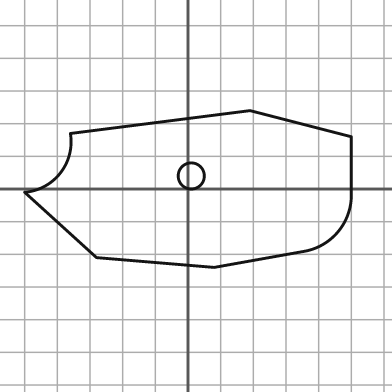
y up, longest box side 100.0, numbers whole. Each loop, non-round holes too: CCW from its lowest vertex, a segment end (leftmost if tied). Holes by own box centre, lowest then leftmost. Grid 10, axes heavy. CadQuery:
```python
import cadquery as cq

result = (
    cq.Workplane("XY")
    .moveTo(8.0, -24.0)
    .lineTo(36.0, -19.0)
    .threePointArc((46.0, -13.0), (50.0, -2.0))
    .lineTo(50.0, 16.0)
    .lineTo(19.0, 24.0)
    .lineTo(-36.0, 17.0)
    .threePointArc((-39.0, 5.0), (-50.0, -1.0))
    .lineTo(-28.0, -21.0)
    .close()
    .moveTo(1.0, 4.0)
    .circle(4.0)
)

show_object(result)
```